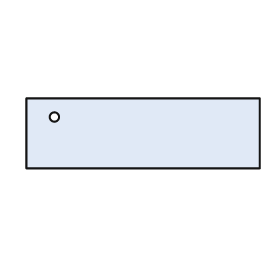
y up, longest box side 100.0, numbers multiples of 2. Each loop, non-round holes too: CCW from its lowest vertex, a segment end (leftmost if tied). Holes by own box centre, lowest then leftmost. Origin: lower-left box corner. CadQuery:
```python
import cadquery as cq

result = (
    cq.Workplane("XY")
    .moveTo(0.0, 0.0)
    .lineTo(100.0, 0.0)
    .lineTo(100.0, 30.0)
    .lineTo(0.0, 30.0)
    .close()
    .moveTo(12.0, 22.0)
    .circle(2.0)
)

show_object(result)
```